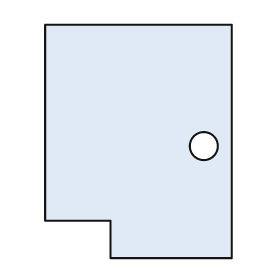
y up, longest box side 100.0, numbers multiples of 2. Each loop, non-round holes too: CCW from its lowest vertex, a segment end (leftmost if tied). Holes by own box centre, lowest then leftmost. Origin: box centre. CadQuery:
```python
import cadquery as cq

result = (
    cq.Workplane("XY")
    .moveTo(-12.0, -50.0)
    .lineTo(40.0, -50.0)
    .lineTo(40.0, 50.0)
    .lineTo(-40.0, 50.0)
    .lineTo(-40.0, -34.0)
    .lineTo(-12.0, -34.0)
    .close()
    .moveTo(28.0, -2.0)
    .circle(6.0)
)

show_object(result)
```